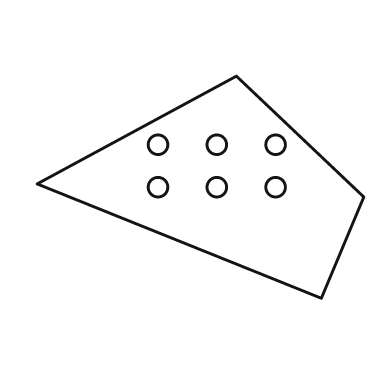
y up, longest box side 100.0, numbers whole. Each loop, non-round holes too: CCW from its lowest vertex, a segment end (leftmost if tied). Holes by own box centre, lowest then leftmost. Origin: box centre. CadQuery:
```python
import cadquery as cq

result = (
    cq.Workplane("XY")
    .moveTo(37.0, -34.0)
    .lineTo(50.0, -3.0)
    .lineTo(11.0, 34.0)
    .lineTo(-50.0, 1.0)
    .close()
    .moveTo(-13.0, 0.0)
    .circle(3.0)
    .moveTo(5.0, 0.0)
    .circle(3.0)
    .moveTo(23.0, 0.0)
    .circle(3.0)
    .moveTo(-13.0, 13.0)
    .circle(3.0)
    .moveTo(5.0, 13.0)
    .circle(3.0)
    .moveTo(23.0, 13.0)
    .circle(3.0)
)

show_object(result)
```